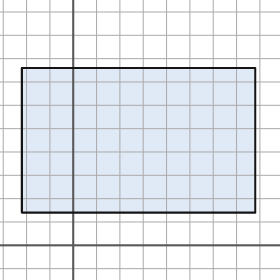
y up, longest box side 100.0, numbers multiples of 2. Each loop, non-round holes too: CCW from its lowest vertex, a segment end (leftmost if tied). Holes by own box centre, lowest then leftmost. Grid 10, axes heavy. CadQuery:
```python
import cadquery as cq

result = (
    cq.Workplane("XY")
    .moveTo(-22.0, 14.0)
    .lineTo(78.0, 14.0)
    .lineTo(78.0, 76.0)
    .lineTo(-22.0, 76.0)
    .close()
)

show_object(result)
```